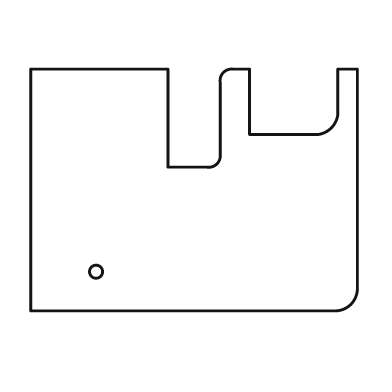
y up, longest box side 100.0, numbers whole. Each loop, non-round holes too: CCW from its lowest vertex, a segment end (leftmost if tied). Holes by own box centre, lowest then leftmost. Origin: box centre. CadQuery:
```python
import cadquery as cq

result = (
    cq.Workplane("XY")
    .moveTo(-50.0, -37.0)
    .lineTo(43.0, -37.0)
    .threePointArc((48.0, -35.0), (50.0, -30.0))
    .lineTo(50.0, 37.0)
    .lineTo(44.0, 37.0)
    .lineTo(44.0, 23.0)
    .threePointArc((42.0, 19.0), (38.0, 17.0))
    .lineTo(17.0, 17.0)
    .lineTo(17.0, 37.0)
    .lineTo(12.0, 37.0)
    .threePointArc((9.0, 36.0), (8.0, 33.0))
    .lineTo(8.0, 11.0)
    .threePointArc((7.0, 8.0), (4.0, 7.0))
    .lineTo(-8.0, 7.0)
    .lineTo(-8.0, 37.0)
    .lineTo(-50.0, 37.0)
    .close()
    .moveTo(-30.0, -25.0)
    .circle(2.0)
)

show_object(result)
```